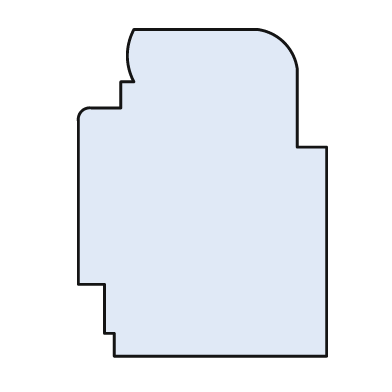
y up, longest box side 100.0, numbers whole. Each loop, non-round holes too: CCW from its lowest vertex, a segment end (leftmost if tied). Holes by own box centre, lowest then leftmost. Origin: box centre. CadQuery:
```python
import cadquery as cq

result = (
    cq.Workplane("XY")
    .moveTo(-27.0, -50.0)
    .lineTo(38.0, -50.0)
    .lineTo(38.0, 14.0)
    .lineTo(29.0, 14.0)
    .lineTo(29.0, 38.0)
    .threePointArc((25.0, 46.0), (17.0, 50.0))
    .lineTo(-21.0, 50.0)
    .threePointArc((-23.0, 42.0), (-21.0, 34.0))
    .lineTo(-25.0, 34.0)
    .lineTo(-25.0, 26.0)
    .lineTo(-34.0, 26.0)
    .threePointArc((-37.0, 25.0), (-38.0, 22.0))
    .lineTo(-38.0, -28.0)
    .lineTo(-30.0, -28.0)
    .lineTo(-30.0, -43.0)
    .lineTo(-27.0, -43.0)
    .close()
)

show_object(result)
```